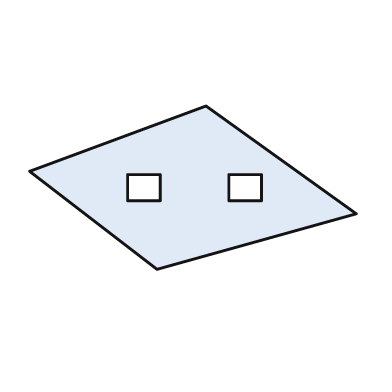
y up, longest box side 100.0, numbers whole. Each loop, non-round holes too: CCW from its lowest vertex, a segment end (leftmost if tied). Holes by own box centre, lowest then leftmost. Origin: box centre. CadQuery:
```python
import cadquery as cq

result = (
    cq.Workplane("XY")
    .moveTo(-11.0, -25.0)
    .lineTo(50.0, -8.0)
    .lineTo(4.0, 25.0)
    .lineTo(-50.0, 5.0)
    .close()
    .moveTo(-20.0, -4.0)
    .lineTo(-10.0, -4.0)
    .lineTo(-10.0, 4.0)
    .lineTo(-20.0, 4.0)
    .close()
    .moveTo(11.0, -4.0)
    .lineTo(21.0, -4.0)
    .lineTo(21.0, 4.0)
    .lineTo(11.0, 4.0)
    .close()
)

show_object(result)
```